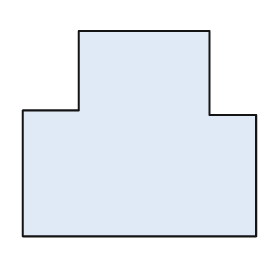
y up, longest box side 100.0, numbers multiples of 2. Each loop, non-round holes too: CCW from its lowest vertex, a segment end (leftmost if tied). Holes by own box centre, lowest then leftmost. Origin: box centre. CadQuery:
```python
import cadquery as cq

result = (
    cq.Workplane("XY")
    .moveTo(-50.0, -44.0)
    .lineTo(50.0, -44.0)
    .lineTo(50.0, 8.0)
    .lineTo(30.0, 8.0)
    .lineTo(30.0, 44.0)
    .lineTo(-26.0, 44.0)
    .lineTo(-26.0, 10.0)
    .lineTo(-50.0, 10.0)
    .close()
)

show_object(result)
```